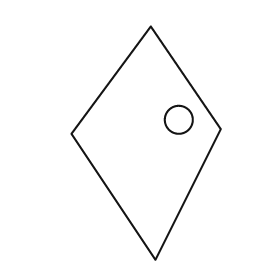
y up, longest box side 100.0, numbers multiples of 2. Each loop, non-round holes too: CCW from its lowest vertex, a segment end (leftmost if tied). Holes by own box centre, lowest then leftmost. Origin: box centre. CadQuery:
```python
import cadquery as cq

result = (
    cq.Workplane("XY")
    .moveTo(4.0, -50.0)
    .lineTo(32.0, 6.0)
    .lineTo(2.0, 50.0)
    .lineTo(-32.0, 4.0)
    .close()
    .moveTo(14.0, 10.0)
    .circle(6.0)
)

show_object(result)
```